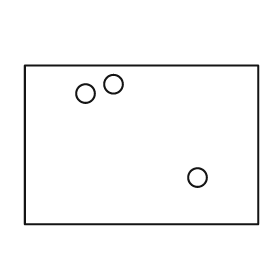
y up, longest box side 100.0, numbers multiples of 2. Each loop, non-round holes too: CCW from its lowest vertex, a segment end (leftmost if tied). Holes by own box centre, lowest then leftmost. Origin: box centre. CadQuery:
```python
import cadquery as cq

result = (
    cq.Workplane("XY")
    .moveTo(-50.0, -34.0)
    .lineTo(50.0, -34.0)
    .lineTo(50.0, 34.0)
    .lineTo(-50.0, 34.0)
    .close()
    .moveTo(24.0, -14.0)
    .circle(4.0)
    .moveTo(-24.0, 22.0)
    .circle(4.0)
    .moveTo(-12.0, 26.0)
    .circle(4.0)
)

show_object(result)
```